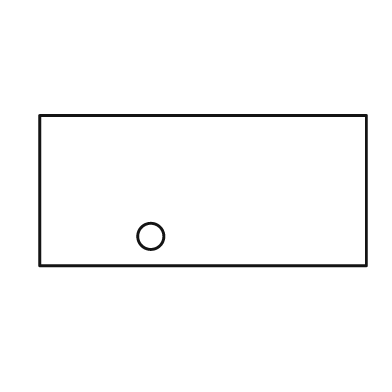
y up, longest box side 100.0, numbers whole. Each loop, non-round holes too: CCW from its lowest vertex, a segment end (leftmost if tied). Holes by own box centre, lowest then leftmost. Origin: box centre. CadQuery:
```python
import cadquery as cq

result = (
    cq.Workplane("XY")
    .moveTo(-50.0, -23.0)
    .lineTo(50.0, -23.0)
    .lineTo(50.0, 23.0)
    .lineTo(-50.0, 23.0)
    .close()
    .moveTo(-16.0, -14.0)
    .circle(4.0)
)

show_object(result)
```